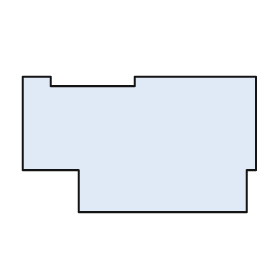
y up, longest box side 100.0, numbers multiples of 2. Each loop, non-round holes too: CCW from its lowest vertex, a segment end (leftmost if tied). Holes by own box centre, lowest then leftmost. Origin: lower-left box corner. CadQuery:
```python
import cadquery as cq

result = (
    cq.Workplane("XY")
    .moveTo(24.0, 0.0)
    .lineTo(96.0, 0.0)
    .lineTo(96.0, 18.0)
    .lineTo(100.0, 18.0)
    .lineTo(100.0, 58.0)
    .lineTo(48.0, 58.0)
    .lineTo(48.0, 54.0)
    .lineTo(12.0, 54.0)
    .lineTo(12.0, 58.0)
    .lineTo(0.0, 58.0)
    .lineTo(0.0, 18.0)
    .lineTo(24.0, 18.0)
    .close()
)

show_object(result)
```